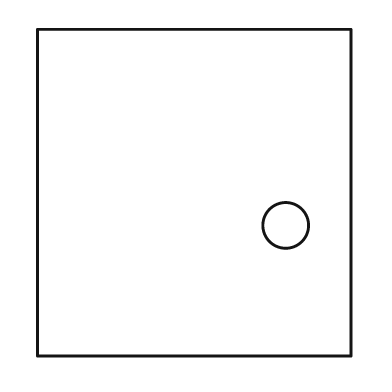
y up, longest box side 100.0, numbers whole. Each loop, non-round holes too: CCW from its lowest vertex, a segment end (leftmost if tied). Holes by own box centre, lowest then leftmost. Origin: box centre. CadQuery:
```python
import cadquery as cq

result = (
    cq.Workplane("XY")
    .moveTo(-48.0, -50.0)
    .lineTo(48.0, -50.0)
    .lineTo(48.0, 50.0)
    .lineTo(-48.0, 50.0)
    .close()
    .moveTo(28.0, -10.0)
    .circle(7.0)
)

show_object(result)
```